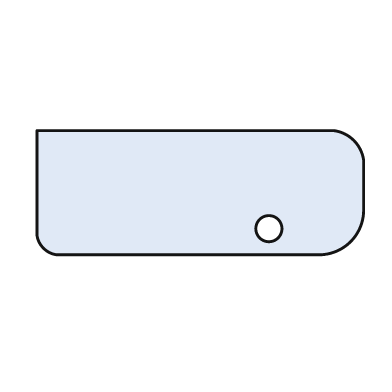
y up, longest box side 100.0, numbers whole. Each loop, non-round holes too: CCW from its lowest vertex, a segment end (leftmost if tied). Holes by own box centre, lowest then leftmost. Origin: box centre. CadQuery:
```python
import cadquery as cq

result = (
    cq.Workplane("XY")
    .moveTo(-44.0, -19.0)
    .lineTo(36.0, -19.0)
    .threePointArc((46.0, -15.0), (50.0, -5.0))
    .lineTo(50.0, 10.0)
    .threePointArc((47.0, 16.0), (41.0, 19.0))
    .lineTo(-50.0, 19.0)
    .lineTo(-50.0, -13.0)
    .threePointArc((-48.0, -17.0), (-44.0, -19.0))
    .close()
    .moveTo(21.0, -11.0)
    .circle(4.0)
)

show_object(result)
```